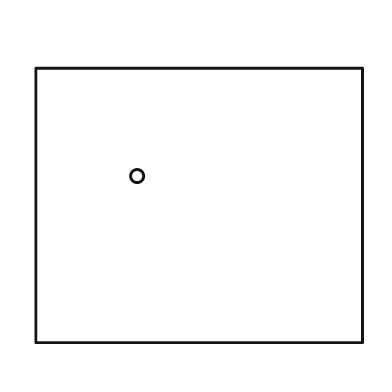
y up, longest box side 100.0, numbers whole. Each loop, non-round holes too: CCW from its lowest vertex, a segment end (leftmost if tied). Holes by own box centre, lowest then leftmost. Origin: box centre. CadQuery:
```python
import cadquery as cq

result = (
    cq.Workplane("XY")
    .moveTo(-50.0, -42.0)
    .lineTo(50.0, -42.0)
    .lineTo(50.0, 42.0)
    .lineTo(-50.0, 42.0)
    .close()
    .moveTo(-19.0, 9.0)
    .circle(2.0)
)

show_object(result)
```